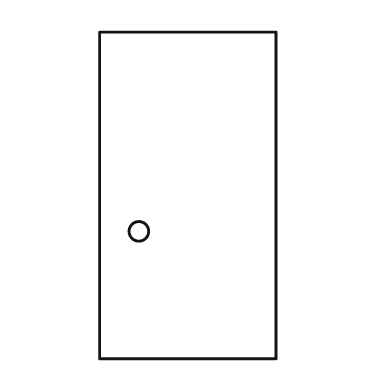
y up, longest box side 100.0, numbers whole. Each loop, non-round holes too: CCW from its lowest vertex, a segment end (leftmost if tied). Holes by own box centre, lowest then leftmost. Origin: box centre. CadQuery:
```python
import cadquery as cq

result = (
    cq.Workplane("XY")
    .moveTo(-27.0, -50.0)
    .lineTo(27.0, -50.0)
    .lineTo(27.0, 50.0)
    .lineTo(-27.0, 50.0)
    .close()
    .moveTo(-15.0, -11.0)
    .circle(3.0)
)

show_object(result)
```